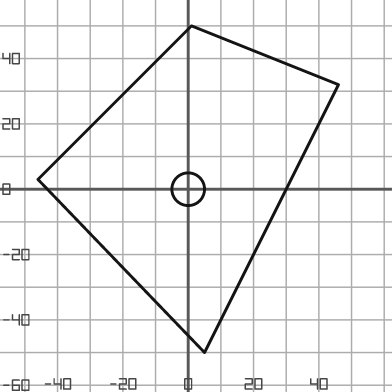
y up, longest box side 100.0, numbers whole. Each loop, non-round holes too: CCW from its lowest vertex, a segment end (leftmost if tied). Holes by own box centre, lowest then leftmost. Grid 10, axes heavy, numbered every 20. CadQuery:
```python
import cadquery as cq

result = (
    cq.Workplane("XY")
    .moveTo(5.0, -50.0)
    .lineTo(46.0, 32.0)
    .lineTo(1.0, 50.0)
    .lineTo(-46.0, 3.0)
    .close()
    .moveTo(0.0, 0.0)
    .circle(5.0)
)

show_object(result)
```